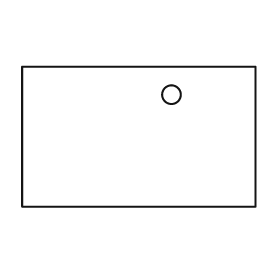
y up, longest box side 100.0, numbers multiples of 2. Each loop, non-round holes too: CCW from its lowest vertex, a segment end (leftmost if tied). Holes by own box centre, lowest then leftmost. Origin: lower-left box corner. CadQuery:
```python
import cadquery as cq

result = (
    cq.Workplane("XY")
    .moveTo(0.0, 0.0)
    .lineTo(100.0, 0.0)
    .lineTo(100.0, 60.0)
    .lineTo(0.0, 60.0)
    .close()
    .moveTo(64.0, 48.0)
    .circle(4.0)
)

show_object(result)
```